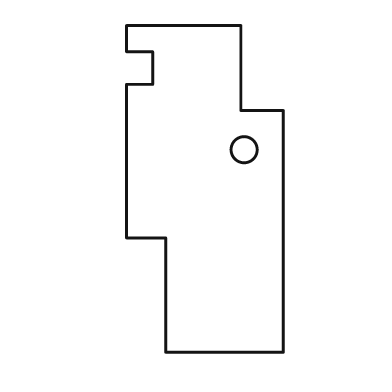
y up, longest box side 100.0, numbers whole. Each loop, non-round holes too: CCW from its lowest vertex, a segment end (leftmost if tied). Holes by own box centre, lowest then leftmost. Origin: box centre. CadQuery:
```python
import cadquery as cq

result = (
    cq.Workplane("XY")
    .moveTo(-12.0, -50.0)
    .lineTo(24.0, -50.0)
    .lineTo(24.0, 24.0)
    .lineTo(11.0, 24.0)
    .lineTo(11.0, 50.0)
    .lineTo(-24.0, 50.0)
    .lineTo(-24.0, 42.0)
    .lineTo(-16.0, 42.0)
    .lineTo(-16.0, 32.0)
    .lineTo(-24.0, 32.0)
    .lineTo(-24.0, -15.0)
    .lineTo(-12.0, -15.0)
    .close()
    .moveTo(12.0, 12.0)
    .circle(4.0)
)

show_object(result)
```